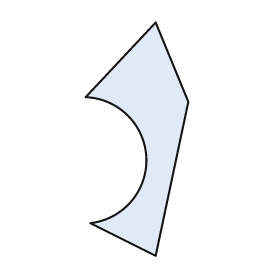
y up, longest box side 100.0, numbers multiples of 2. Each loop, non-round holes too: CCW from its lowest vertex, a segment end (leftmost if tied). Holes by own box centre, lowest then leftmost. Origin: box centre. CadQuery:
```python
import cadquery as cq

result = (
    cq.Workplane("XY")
    .moveTo(8.0, -50.0)
    .lineTo(22.0, 16.0)
    .lineTo(8.0, 50.0)
    .lineTo(-22.0, 18.0)
    .threePointArc((4.0, -8.0), (-20.0, -36.0))
    .close()
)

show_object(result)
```